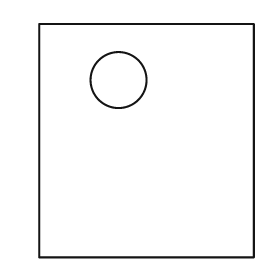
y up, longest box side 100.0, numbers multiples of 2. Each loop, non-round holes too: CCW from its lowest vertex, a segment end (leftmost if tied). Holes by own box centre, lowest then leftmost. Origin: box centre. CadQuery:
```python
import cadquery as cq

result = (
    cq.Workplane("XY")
    .moveTo(-46.0, -50.0)
    .lineTo(46.0, -50.0)
    .lineTo(46.0, 50.0)
    .lineTo(-46.0, 50.0)
    .close()
    .moveTo(-12.0, 26.0)
    .circle(12.0)
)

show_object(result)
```